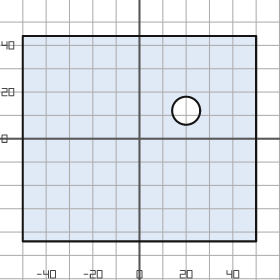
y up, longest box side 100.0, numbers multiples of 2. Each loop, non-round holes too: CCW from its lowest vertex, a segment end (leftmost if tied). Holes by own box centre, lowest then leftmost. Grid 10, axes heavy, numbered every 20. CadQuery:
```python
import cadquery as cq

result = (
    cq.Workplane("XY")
    .moveTo(-50.0, -44.0)
    .lineTo(50.0, -44.0)
    .lineTo(50.0, 44.0)
    .lineTo(-50.0, 44.0)
    .close()
    .moveTo(20.0, 12.0)
    .circle(6.0)
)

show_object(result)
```